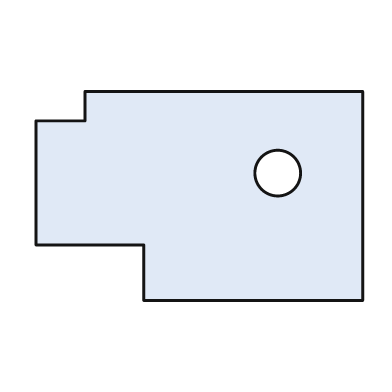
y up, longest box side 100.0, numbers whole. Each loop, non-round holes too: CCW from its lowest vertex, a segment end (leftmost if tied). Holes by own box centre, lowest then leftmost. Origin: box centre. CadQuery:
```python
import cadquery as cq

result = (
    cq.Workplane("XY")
    .moveTo(-17.0, -32.0)
    .lineTo(50.0, -32.0)
    .lineTo(50.0, 32.0)
    .lineTo(-35.0, 32.0)
    .lineTo(-35.0, 23.0)
    .lineTo(-50.0, 23.0)
    .lineTo(-50.0, -15.0)
    .lineTo(-17.0, -15.0)
    .close()
    .moveTo(24.0, 7.0)
    .circle(7.0)
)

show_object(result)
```